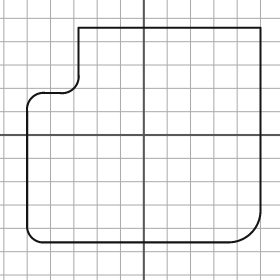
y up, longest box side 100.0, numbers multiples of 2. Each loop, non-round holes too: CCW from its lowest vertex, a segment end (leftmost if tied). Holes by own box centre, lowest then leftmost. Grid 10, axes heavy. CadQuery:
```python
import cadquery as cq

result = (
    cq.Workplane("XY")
    .moveTo(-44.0, -46.0)
    .lineTo(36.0, -46.0)
    .threePointArc((46.0, -42.0), (50.0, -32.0))
    .lineTo(50.0, 46.0)
    .lineTo(-28.0, 46.0)
    .lineTo(-28.0, 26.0)
    .threePointArc((-30.0, 20.0), (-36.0, 18.0))
    .lineTo(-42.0, 18.0)
    .threePointArc((-48.0, 16.0), (-50.0, 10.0))
    .lineTo(-50.0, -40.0)
    .threePointArc((-48.0, -44.0), (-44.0, -46.0))
    .close()
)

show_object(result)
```